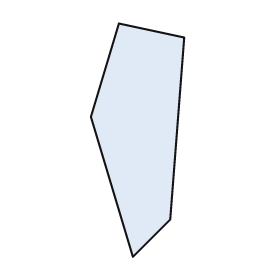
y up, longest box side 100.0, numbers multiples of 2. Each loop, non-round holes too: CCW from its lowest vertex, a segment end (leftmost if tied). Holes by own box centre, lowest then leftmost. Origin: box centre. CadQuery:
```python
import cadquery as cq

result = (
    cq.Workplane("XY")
    .moveTo(-2.0, -50.0)
    .lineTo(14.0, -34.0)
    .lineTo(20.0, 44.0)
    .lineTo(-8.0, 50.0)
    .lineTo(-20.0, 10.0)
    .close()
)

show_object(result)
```